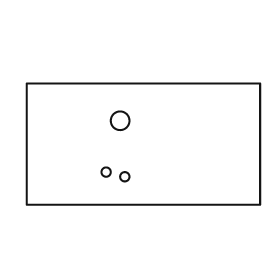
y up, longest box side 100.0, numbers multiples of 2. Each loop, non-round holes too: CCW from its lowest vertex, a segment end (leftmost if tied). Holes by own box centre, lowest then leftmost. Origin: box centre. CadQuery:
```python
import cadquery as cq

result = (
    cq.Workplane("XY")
    .moveTo(-50.0, -26.0)
    .lineTo(50.0, -26.0)
    .lineTo(50.0, 26.0)
    .lineTo(-50.0, 26.0)
    .close()
    .moveTo(-8.0, -14.0)
    .circle(2.0)
    .moveTo(-16.0, -12.0)
    .circle(2.0)
    .moveTo(-10.0, 10.0)
    .circle(4.0)
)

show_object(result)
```